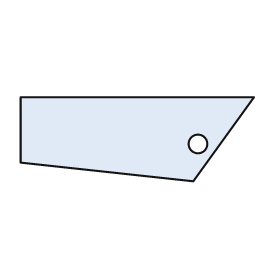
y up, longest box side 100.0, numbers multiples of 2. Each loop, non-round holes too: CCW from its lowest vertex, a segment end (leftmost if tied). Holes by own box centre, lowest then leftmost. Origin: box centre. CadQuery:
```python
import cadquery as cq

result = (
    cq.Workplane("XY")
    .moveTo(24.0, -18.0)
    .lineTo(50.0, 18.0)
    .lineTo(-50.0, 18.0)
    .lineTo(-50.0, -10.0)
    .close()
    .moveTo(26.0, -2.0)
    .circle(4.0)
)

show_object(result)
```